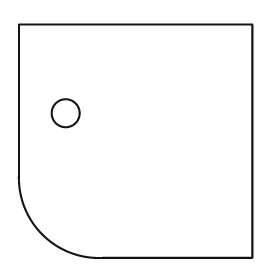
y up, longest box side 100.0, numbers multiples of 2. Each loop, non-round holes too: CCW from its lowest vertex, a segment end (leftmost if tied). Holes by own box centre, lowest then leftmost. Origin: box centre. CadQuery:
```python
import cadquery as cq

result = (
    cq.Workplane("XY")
    .moveTo(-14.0, -50.0)
    .lineTo(50.0, -50.0)
    .lineTo(50.0, 50.0)
    .lineTo(-50.0, 50.0)
    .lineTo(-50.0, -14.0)
    .threePointArc((-40.0, -40.0), (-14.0, -50.0))
    .close()
    .moveTo(-30.0, 12.0)
    .circle(6.0)
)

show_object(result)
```